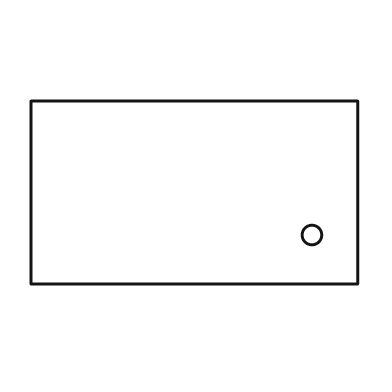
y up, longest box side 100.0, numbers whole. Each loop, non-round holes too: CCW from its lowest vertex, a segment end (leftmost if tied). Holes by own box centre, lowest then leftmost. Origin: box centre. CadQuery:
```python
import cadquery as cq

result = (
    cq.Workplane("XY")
    .moveTo(-50.0, -28.0)
    .lineTo(50.0, -28.0)
    .lineTo(50.0, 28.0)
    .lineTo(-50.0, 28.0)
    .close()
    .moveTo(36.0, -13.0)
    .circle(3.0)
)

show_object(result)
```